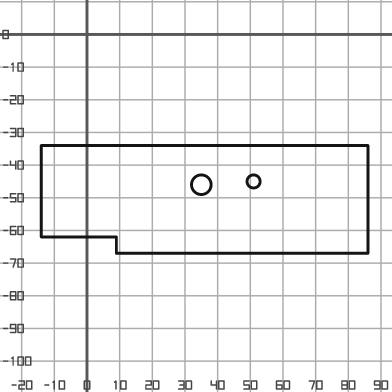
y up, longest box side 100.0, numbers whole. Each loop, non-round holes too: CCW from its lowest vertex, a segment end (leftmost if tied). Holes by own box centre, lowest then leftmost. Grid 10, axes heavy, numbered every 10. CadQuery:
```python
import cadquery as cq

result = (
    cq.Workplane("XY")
    .moveTo(9.0, -67.0)
    .lineTo(86.0, -67.0)
    .lineTo(86.0, -34.0)
    .lineTo(-14.0, -34.0)
    .lineTo(-14.0, -62.0)
    .lineTo(9.0, -62.0)
    .close()
    .moveTo(35.0, -46.0)
    .circle(3.0)
    .moveTo(51.0, -45.0)
    .circle(2.0)
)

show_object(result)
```